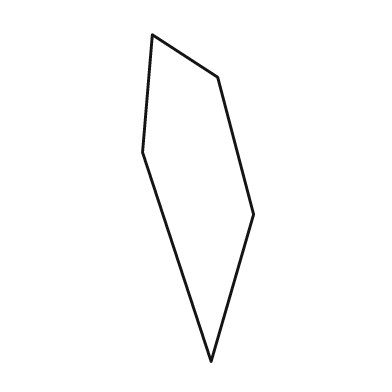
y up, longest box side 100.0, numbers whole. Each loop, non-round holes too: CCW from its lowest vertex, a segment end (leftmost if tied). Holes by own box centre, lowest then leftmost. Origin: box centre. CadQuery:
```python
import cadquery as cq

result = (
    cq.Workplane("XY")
    .moveTo(4.0, -50.0)
    .lineTo(17.0, -5.0)
    .lineTo(6.0, 37.0)
    .lineTo(-14.0, 50.0)
    .lineTo(-17.0, 14.0)
    .close()
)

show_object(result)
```